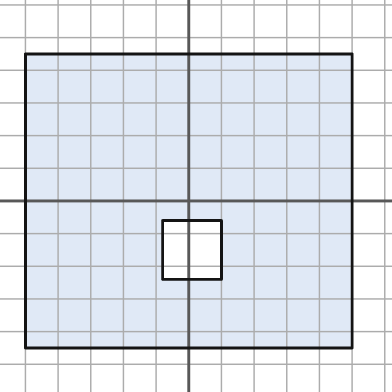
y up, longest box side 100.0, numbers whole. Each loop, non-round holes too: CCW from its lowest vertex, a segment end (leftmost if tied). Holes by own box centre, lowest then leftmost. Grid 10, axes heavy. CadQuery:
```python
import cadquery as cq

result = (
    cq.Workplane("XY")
    .moveTo(-50.0, -45.0)
    .lineTo(50.0, -45.0)
    .lineTo(50.0, 45.0)
    .lineTo(-50.0, 45.0)
    .close()
    .moveTo(-8.0, -24.0)
    .lineTo(10.0, -24.0)
    .lineTo(10.0, -6.0)
    .lineTo(-8.0, -6.0)
    .close()
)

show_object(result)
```